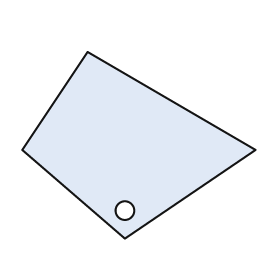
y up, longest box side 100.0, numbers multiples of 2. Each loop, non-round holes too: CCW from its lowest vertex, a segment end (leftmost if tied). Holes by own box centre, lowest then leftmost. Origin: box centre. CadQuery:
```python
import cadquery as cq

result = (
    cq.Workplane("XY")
    .moveTo(-6.0, -40.0)
    .lineTo(50.0, -2.0)
    .lineTo(-22.0, 40.0)
    .lineTo(-50.0, -2.0)
    .close()
    .moveTo(-6.0, -28.0)
    .circle(4.0)
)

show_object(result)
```